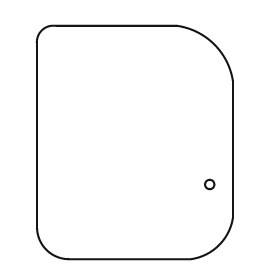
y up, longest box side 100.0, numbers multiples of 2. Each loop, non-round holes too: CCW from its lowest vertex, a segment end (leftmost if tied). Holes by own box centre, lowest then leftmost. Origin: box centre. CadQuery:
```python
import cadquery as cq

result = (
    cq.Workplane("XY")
    .moveTo(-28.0, -50.0)
    .lineTo(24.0, -50.0)
    .threePointArc((36.0, -44.0), (42.0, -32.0))
    .lineTo(42.0, 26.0)
    .threePointArc((34.0, 42.0), (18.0, 50.0))
    .lineTo(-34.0, 50.0)
    .threePointArc((-40.0, 48.0), (-42.0, 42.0))
    .lineTo(-42.0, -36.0)
    .threePointArc((-38.0, -46.0), (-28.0, -50.0))
    .close()
    .moveTo(32.0, -18.0)
    .circle(2.0)
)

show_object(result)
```